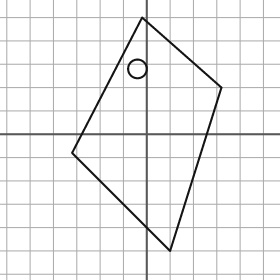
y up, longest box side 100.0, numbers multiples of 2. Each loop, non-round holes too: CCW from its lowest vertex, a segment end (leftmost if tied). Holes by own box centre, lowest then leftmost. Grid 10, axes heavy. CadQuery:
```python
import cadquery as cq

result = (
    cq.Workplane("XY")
    .moveTo(10.0, -50.0)
    .lineTo(32.0, 20.0)
    .lineTo(-2.0, 50.0)
    .lineTo(-32.0, -8.0)
    .close()
    .moveTo(-4.0, 28.0)
    .circle(4.0)
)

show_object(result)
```